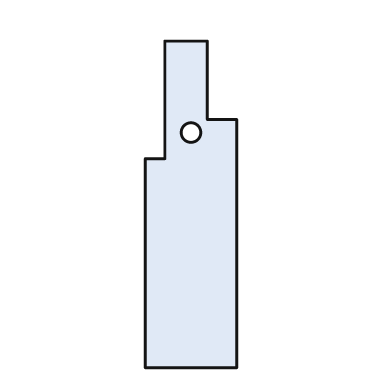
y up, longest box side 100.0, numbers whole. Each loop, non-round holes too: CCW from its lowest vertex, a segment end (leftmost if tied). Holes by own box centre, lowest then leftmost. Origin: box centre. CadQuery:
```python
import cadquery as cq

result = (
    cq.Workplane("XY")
    .moveTo(-14.0, -50.0)
    .lineTo(14.0, -50.0)
    .lineTo(14.0, 26.0)
    .lineTo(5.0, 26.0)
    .lineTo(5.0, 50.0)
    .lineTo(-8.0, 50.0)
    .lineTo(-8.0, 14.0)
    .lineTo(-14.0, 14.0)
    .close()
    .moveTo(0.0, 22.0)
    .circle(3.0)
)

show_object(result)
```